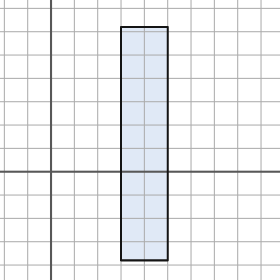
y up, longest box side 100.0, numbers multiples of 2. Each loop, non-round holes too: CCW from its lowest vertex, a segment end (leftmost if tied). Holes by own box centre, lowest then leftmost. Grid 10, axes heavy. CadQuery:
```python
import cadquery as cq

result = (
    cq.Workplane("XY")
    .moveTo(30.0, -38.0)
    .lineTo(50.0, -38.0)
    .lineTo(50.0, 62.0)
    .lineTo(30.0, 62.0)
    .close()
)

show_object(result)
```